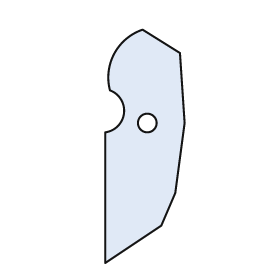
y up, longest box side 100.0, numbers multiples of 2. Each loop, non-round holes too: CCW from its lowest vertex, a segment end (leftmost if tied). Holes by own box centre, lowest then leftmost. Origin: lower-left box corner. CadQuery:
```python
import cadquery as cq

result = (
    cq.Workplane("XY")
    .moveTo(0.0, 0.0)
    .lineTo(24.0, 16.0)
    .lineTo(30.0, 30.0)
    .lineTo(34.0, 60.0)
    .lineTo(32.0, 90.0)
    .lineTo(16.0, 100.0)
    .threePointArc((4.0, 90.0), (2.0, 74.0))
    .threePointArc((8.0, 64.0), (0.0, 56.0))
    .close()
    .moveTo(18.0, 60.0)
    .circle(4.0)
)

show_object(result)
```